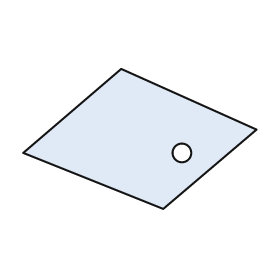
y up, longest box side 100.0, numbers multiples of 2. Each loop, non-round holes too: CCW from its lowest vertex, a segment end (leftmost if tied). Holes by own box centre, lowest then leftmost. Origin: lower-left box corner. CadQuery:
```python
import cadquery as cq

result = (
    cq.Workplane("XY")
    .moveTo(60.0, 0.0)
    .lineTo(100.0, 34.0)
    .lineTo(42.0, 60.0)
    .lineTo(0.0, 24.0)
    .close()
    .moveTo(68.0, 24.0)
    .circle(4.0)
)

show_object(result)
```